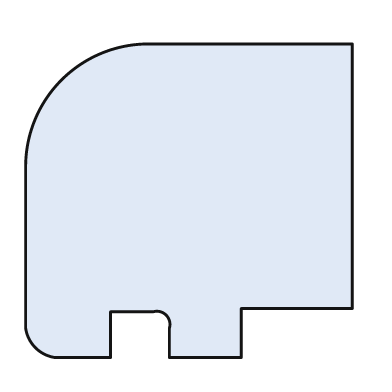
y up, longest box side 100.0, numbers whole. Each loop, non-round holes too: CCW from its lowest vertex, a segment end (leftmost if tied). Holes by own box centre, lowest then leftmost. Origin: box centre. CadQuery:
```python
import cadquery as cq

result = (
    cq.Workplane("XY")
    .moveTo(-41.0, -48.0)
    .lineTo(-24.0, -48.0)
    .lineTo(-24.0, -34.0)
    .lineTo(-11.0, -34.0)
    .threePointArc((-7.0, -35.0), (-6.0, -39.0))
    .lineTo(-6.0, -48.0)
    .lineTo(16.0, -48.0)
    .lineTo(16.0, -33.0)
    .lineTo(50.0, -33.0)
    .lineTo(50.0, 48.0)
    .lineTo(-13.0, 48.0)
    .threePointArc((-39.0, 37.0), (-50.0, 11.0))
    .lineTo(-50.0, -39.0)
    .threePointArc((-47.0, -45.0), (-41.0, -48.0))
    .close()
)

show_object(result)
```